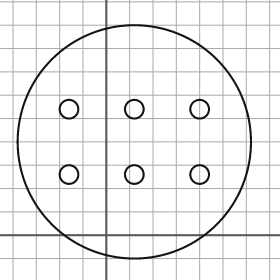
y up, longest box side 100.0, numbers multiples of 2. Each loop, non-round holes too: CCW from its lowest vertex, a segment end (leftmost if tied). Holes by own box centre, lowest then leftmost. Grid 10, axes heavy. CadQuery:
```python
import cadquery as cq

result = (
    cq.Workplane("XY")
    .moveTo(12.0, 40.0)
    .circle(50.0)
    .moveTo(-16.0, 26.0)
    .circle(4.0)
    .moveTo(12.0, 26.0)
    .circle(4.0)
    .moveTo(40.0, 26.0)
    .circle(4.0)
    .moveTo(-16.0, 54.0)
    .circle(4.0)
    .moveTo(12.0, 54.0)
    .circle(4.0)
    .moveTo(40.0, 54.0)
    .circle(4.0)
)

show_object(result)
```